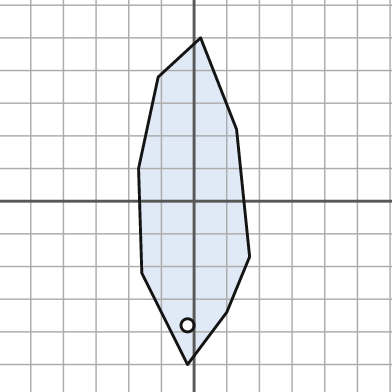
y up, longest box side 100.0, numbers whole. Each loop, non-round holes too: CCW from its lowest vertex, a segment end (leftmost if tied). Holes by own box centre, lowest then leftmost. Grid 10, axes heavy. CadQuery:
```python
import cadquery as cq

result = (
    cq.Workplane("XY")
    .moveTo(-2.0, -50.0)
    .lineTo(10.0, -34.0)
    .lineTo(17.0, -17.0)
    .lineTo(13.0, 22.0)
    .lineTo(2.0, 50.0)
    .lineTo(-11.0, 38.0)
    .lineTo(-17.0, 10.0)
    .lineTo(-16.0, -22.0)
    .close()
    .moveTo(-2.0, -38.0)
    .circle(2.0)
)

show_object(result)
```